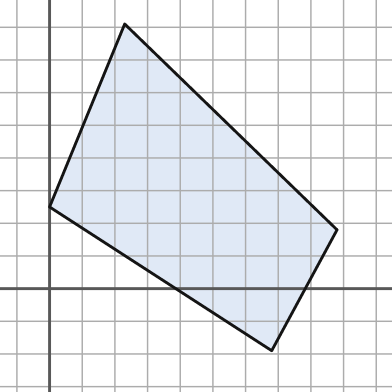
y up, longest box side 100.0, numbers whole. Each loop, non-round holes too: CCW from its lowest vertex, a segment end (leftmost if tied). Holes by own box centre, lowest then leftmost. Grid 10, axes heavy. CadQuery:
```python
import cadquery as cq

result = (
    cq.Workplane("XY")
    .moveTo(68.0, -19.0)
    .lineTo(88.0, 18.0)
    .lineTo(23.0, 81.0)
    .lineTo(0.0, 25.0)
    .close()
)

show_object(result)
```